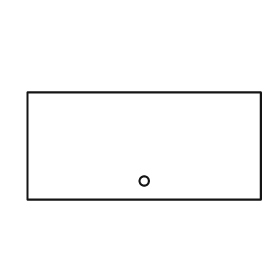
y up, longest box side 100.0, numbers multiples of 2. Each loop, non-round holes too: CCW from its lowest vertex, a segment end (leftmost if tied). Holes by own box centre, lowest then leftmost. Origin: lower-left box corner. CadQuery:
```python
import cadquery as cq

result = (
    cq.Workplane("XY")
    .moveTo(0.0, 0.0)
    .lineTo(100.0, 0.0)
    .lineTo(100.0, 46.0)
    .lineTo(0.0, 46.0)
    .close()
    .moveTo(50.0, 8.0)
    .circle(2.0)
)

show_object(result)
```